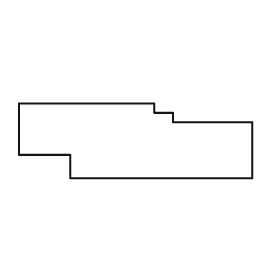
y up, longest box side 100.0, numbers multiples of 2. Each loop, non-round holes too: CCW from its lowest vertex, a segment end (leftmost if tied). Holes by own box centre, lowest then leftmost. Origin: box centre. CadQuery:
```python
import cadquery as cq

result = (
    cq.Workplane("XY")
    .moveTo(-28.0, -16.0)
    .lineTo(50.0, -16.0)
    .lineTo(50.0, 8.0)
    .lineTo(16.0, 8.0)
    .lineTo(16.0, 12.0)
    .lineTo(8.0, 12.0)
    .lineTo(8.0, 16.0)
    .lineTo(-50.0, 16.0)
    .lineTo(-50.0, -6.0)
    .lineTo(-28.0, -6.0)
    .close()
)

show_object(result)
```